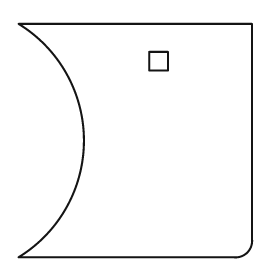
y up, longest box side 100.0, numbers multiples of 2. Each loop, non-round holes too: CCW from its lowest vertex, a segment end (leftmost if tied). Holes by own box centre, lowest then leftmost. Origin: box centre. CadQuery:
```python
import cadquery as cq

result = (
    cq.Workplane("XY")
    .moveTo(-50.0, -50.0)
    .lineTo(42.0, -50.0)
    .threePointArc((48.0, -48.0), (50.0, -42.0))
    .lineTo(50.0, 50.0)
    .lineTo(-50.0, 50.0)
    .threePointArc((-22.0, 0.0), (-50.0, -50.0))
    .close()
    .moveTo(6.0, 30.0)
    .lineTo(14.0, 30.0)
    .lineTo(14.0, 38.0)
    .lineTo(6.0, 38.0)
    .close()
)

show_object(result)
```